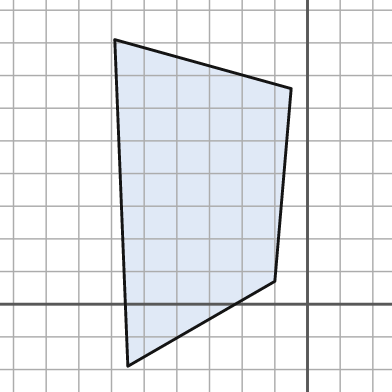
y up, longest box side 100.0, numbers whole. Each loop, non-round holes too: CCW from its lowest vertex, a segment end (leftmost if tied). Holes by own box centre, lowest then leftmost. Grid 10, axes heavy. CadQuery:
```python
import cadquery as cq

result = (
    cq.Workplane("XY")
    .moveTo(-55.0, -19.0)
    .lineTo(-10.0, 7.0)
    .lineTo(-5.0, 66.0)
    .lineTo(-59.0, 81.0)
    .close()
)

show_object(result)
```